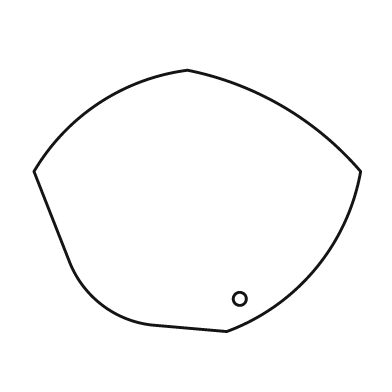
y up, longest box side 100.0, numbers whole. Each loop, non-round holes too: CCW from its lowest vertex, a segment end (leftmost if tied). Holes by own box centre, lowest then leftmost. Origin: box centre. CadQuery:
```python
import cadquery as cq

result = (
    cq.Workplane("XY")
    .moveTo(9.0, -40.0)
    .threePointArc((36.0, -21.0), (50.0, 9.0))
    .threePointArc((26.0, 29.0), (-3.0, 40.0))
    .threePointArc((-30.0, 30.0), (-50.0, 9.0))
    .lineTo(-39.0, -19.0)
    .threePointArc((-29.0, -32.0), (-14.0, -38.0))
    .close()
    .moveTo(13.0, -30.0)
    .circle(2.0)
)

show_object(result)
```